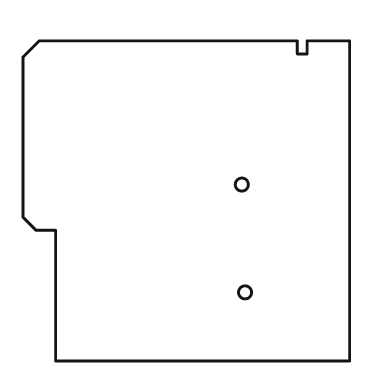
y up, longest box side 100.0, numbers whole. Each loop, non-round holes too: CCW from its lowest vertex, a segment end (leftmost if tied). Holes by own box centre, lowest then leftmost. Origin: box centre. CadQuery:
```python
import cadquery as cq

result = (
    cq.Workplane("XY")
    .moveTo(-40.0, -49.0)
    .lineTo(50.0, -49.0)
    .lineTo(50.0, 49.0)
    .lineTo(37.0, 49.0)
    .lineTo(37.0, 45.0)
    .lineTo(34.0, 45.0)
    .lineTo(34.0, 49.0)
    .lineTo(-45.0, 49.0)
    .lineTo(-50.0, 44.0)
    .lineTo(-50.0, -5.0)
    .lineTo(-46.0, -9.0)
    .lineTo(-40.0, -9.0)
    .close()
    .moveTo(18.0, -28.0)
    .circle(2.0)
    .moveTo(17.0, 5.0)
    .circle(2.0)
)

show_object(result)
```